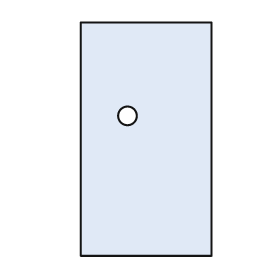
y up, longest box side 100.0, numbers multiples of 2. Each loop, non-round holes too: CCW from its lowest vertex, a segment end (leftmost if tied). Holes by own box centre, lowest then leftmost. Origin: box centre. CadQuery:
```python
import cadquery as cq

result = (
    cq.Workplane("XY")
    .moveTo(-28.0, -50.0)
    .lineTo(28.0, -50.0)
    .lineTo(28.0, 50.0)
    .lineTo(-28.0, 50.0)
    .close()
    .moveTo(-8.0, 10.0)
    .circle(4.0)
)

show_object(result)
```